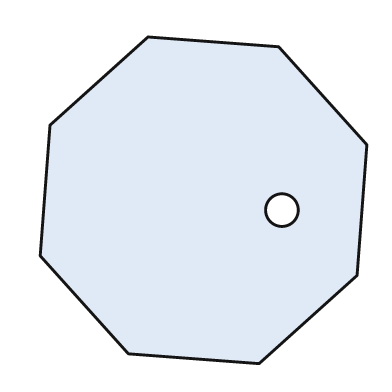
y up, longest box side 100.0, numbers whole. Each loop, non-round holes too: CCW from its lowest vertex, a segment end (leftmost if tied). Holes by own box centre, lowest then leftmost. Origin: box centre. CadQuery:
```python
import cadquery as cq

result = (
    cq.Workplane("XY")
    .moveTo(17.0, -50.0)
    .lineTo(47.0, -23.0)
    .lineTo(50.0, 17.0)
    .lineTo(23.0, 47.0)
    .lineTo(-17.0, 50.0)
    .lineTo(-47.0, 23.0)
    .lineTo(-50.0, -17.0)
    .lineTo(-23.0, -47.0)
    .close()
    .moveTo(24.0, -3.0)
    .circle(5.0)
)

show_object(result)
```